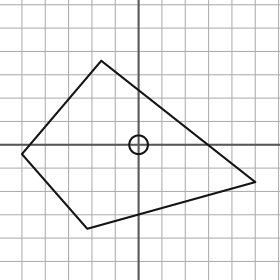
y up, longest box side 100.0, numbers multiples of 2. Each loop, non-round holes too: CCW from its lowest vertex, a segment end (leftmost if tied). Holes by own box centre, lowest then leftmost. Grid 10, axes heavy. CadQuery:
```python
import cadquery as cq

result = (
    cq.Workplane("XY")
    .moveTo(-22.0, -36.0)
    .lineTo(50.0, -16.0)
    .lineTo(-16.0, 36.0)
    .lineTo(-50.0, -4.0)
    .close()
    .moveTo(0.0, 0.0)
    .circle(4.0)
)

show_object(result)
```